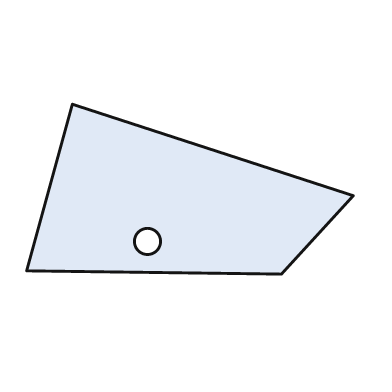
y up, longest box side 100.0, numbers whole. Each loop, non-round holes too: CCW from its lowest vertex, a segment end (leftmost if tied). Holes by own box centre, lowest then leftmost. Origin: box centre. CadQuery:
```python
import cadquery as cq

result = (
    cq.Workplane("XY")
    .moveTo(28.0, -26.0)
    .lineTo(50.0, -2.0)
    .lineTo(-36.0, 26.0)
    .lineTo(-50.0, -25.0)
    .close()
    .moveTo(-13.0, -16.0)
    .circle(4.0)
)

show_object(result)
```